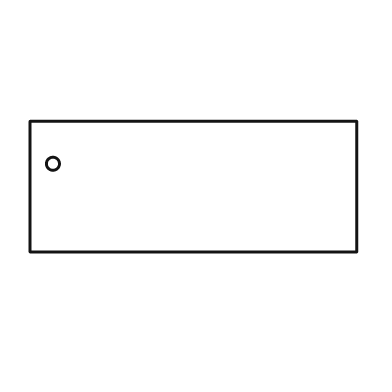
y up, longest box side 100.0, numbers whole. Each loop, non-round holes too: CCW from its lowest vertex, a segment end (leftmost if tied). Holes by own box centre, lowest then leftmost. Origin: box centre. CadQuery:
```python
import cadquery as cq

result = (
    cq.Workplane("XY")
    .moveTo(-50.0, -20.0)
    .lineTo(50.0, -20.0)
    .lineTo(50.0, 20.0)
    .lineTo(-50.0, 20.0)
    .close()
    .moveTo(-43.0, 7.0)
    .circle(2.0)
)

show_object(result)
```